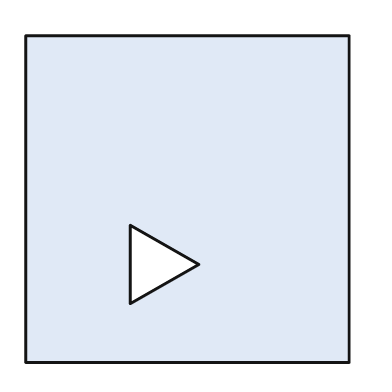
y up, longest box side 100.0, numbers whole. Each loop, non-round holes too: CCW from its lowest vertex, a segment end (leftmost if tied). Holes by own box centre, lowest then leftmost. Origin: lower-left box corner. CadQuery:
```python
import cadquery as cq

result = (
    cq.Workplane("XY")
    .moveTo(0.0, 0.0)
    .lineTo(99.0, 0.0)
    .lineTo(99.0, 100.0)
    .lineTo(0.0, 100.0)
    .close()
    .moveTo(32.0, 18.0)
    .lineTo(53.0, 30.0)
    .lineTo(32.0, 42.0)
    .close()
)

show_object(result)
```